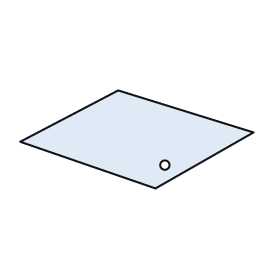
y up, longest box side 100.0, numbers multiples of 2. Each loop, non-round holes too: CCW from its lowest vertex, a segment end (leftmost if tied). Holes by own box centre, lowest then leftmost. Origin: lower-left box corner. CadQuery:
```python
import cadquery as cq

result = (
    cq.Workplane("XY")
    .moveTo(58.0, 0.0)
    .lineTo(100.0, 24.0)
    .lineTo(42.0, 42.0)
    .lineTo(0.0, 20.0)
    .close()
    .moveTo(62.0, 10.0)
    .circle(2.0)
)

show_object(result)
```